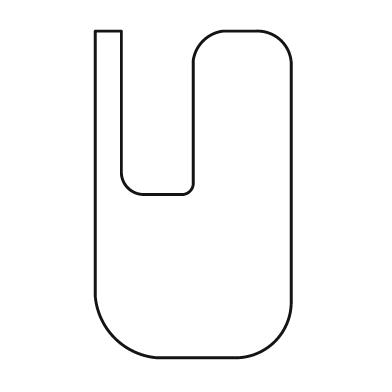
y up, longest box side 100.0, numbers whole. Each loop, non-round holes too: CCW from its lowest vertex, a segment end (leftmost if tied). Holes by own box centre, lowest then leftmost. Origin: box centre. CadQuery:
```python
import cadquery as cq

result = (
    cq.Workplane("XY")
    .moveTo(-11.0, -50.0)
    .lineTo(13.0, -50.0)
    .threePointArc((25.0, -45.0), (30.0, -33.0))
    .lineTo(30.0, 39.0)
    .threePointArc((27.0, 47.0), (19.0, 50.0))
    .lineTo(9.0, 50.0)
    .threePointArc((3.0, 47.0), (0.0, 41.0))
    .lineTo(0.0, 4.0)
    .threePointArc((-1.0, 1.0), (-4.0, 0.0))
    .lineTo(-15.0, 0.0)
    .threePointArc((-20.0, 2.0), (-22.0, 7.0))
    .lineTo(-22.0, 50.0)
    .lineTo(-30.0, 50.0)
    .lineTo(-30.0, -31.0)
    .threePointArc((-24.0, -44.0), (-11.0, -50.0))
    .close()
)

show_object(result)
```